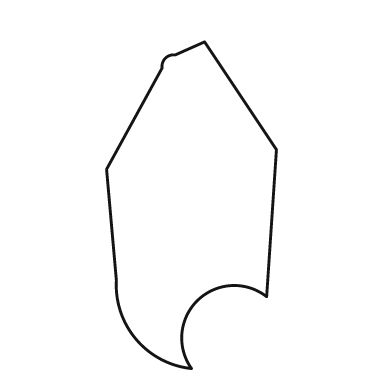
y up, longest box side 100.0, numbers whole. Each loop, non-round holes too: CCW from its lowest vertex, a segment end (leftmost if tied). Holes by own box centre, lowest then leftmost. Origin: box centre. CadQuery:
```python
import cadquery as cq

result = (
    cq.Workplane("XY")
    .moveTo(0.0, -50.0)
    .threePointArc((2.0, -29.0), (23.0, -28.0))
    .lineTo(26.0, 17.0)
    .lineTo(4.0, 50.0)
    .lineTo(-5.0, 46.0)
    .threePointArc((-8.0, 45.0), (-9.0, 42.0))
    .lineTo(-26.0, 11.0)
    .lineTo(-23.0, -23.0)
    .threePointArc((-17.0, -41.0), (0.0, -50.0))
    .close()
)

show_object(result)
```